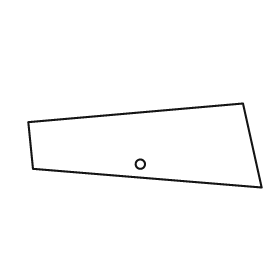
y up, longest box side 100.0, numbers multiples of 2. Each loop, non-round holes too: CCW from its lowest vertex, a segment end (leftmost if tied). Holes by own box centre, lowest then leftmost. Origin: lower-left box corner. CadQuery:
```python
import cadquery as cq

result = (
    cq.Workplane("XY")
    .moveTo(100.0, 0.0)
    .lineTo(92.0, 36.0)
    .lineTo(0.0, 28.0)
    .lineTo(2.0, 8.0)
    .close()
    .moveTo(48.0, 10.0)
    .circle(2.0)
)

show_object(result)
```